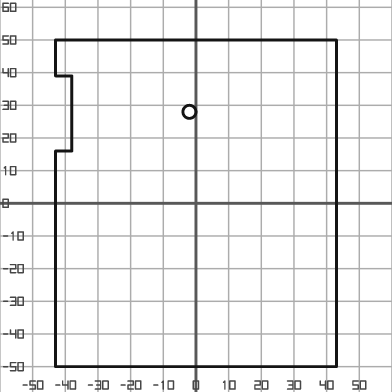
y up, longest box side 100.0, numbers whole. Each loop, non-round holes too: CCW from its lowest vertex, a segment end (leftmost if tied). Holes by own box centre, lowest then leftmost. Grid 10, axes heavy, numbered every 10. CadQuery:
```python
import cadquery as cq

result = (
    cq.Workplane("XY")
    .moveTo(-43.0, -50.0)
    .lineTo(43.0, -50.0)
    .lineTo(43.0, 50.0)
    .lineTo(-43.0, 50.0)
    .lineTo(-43.0, 39.0)
    .lineTo(-38.0, 39.0)
    .lineTo(-38.0, 16.0)
    .lineTo(-43.0, 16.0)
    .close()
    .moveTo(-2.0, 28.0)
    .circle(2.0)
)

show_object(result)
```